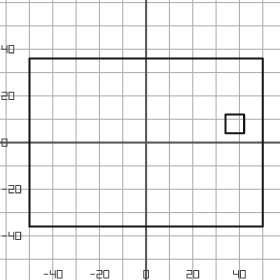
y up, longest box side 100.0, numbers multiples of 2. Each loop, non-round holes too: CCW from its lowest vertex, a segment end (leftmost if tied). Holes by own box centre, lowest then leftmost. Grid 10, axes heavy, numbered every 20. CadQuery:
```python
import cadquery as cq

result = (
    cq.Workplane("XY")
    .moveTo(-50.0, -36.0)
    .lineTo(50.0, -36.0)
    .lineTo(50.0, 36.0)
    .lineTo(-50.0, 36.0)
    .close()
    .moveTo(34.0, 4.0)
    .lineTo(42.0, 4.0)
    .lineTo(42.0, 12.0)
    .lineTo(34.0, 12.0)
    .close()
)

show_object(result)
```